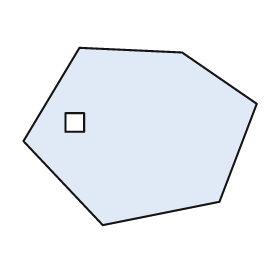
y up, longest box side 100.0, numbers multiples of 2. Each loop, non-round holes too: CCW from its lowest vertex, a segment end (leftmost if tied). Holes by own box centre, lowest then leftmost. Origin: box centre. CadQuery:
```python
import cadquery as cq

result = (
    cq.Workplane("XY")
    .moveTo(-16.0, -38.0)
    .lineTo(34.0, -28.0)
    .lineTo(50.0, 14.0)
    .lineTo(18.0, 36.0)
    .lineTo(-26.0, 38.0)
    .lineTo(-50.0, -2.0)
    .close()
    .moveTo(-32.0, 2.0)
    .lineTo(-24.0, 2.0)
    .lineTo(-24.0, 10.0)
    .lineTo(-32.0, 10.0)
    .close()
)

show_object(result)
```